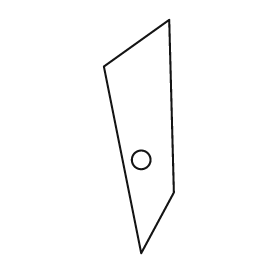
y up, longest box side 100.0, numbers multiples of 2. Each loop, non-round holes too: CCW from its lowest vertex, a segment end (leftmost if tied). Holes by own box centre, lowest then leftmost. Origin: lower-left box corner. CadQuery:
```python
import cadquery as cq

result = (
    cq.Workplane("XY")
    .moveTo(16.0, 0.0)
    .lineTo(30.0, 26.0)
    .lineTo(28.0, 100.0)
    .lineTo(0.0, 80.0)
    .close()
    .moveTo(16.0, 40.0)
    .circle(4.0)
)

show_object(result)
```